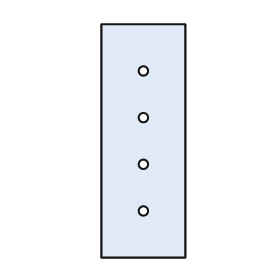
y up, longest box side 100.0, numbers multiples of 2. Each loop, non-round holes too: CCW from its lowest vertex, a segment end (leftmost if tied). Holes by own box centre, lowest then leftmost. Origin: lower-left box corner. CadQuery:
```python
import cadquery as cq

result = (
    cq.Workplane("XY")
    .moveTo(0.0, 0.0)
    .lineTo(36.0, 0.0)
    .lineTo(36.0, 100.0)
    .lineTo(0.0, 100.0)
    .close()
    .moveTo(18.0, 20.0)
    .circle(2.0)
    .moveTo(18.0, 40.0)
    .circle(2.0)
    .moveTo(18.0, 60.0)
    .circle(2.0)
    .moveTo(18.0, 80.0)
    .circle(2.0)
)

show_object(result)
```